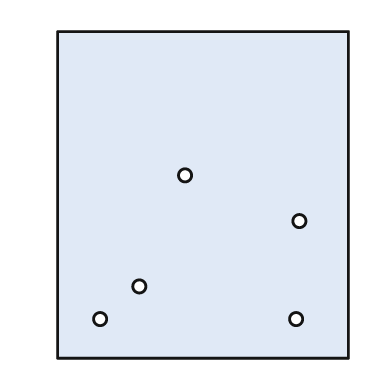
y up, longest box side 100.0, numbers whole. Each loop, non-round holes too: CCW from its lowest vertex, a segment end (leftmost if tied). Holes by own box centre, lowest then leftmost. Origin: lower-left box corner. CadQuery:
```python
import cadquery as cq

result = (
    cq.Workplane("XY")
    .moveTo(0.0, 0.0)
    .lineTo(89.0, 0.0)
    .lineTo(89.0, 100.0)
    .lineTo(0.0, 100.0)
    .close()
    .moveTo(13.0, 12.0)
    .circle(2.0)
    .moveTo(73.0, 12.0)
    .circle(2.0)
    .moveTo(25.0, 22.0)
    .circle(2.0)
    .moveTo(74.0, 42.0)
    .circle(2.0)
    .moveTo(39.0, 56.0)
    .circle(2.0)
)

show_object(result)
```